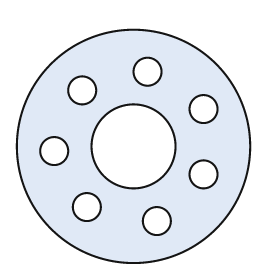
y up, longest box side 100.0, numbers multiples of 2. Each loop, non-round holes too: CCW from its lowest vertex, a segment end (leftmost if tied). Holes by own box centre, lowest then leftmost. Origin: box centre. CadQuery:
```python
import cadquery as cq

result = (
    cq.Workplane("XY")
    .moveTo(0.0, 0.0)
    .circle(50.0)
    .moveTo(10.0, -32.0)
    .circle(6.0)
    .moveTo(-20.0, -26.0)
    .circle(6.0)
    .moveTo(30.0, -12.0)
    .circle(6.0)
    .moveTo(-34.0, -2.0)
    .circle(6.0)
    .moveTo(0.0, 0.0)
    .circle(18.0)
    .moveTo(30.0, 16.0)
    .circle(6.0)
    .moveTo(-22.0, 24.0)
    .circle(6.0)
    .moveTo(6.0, 32.0)
    .circle(6.0)
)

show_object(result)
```